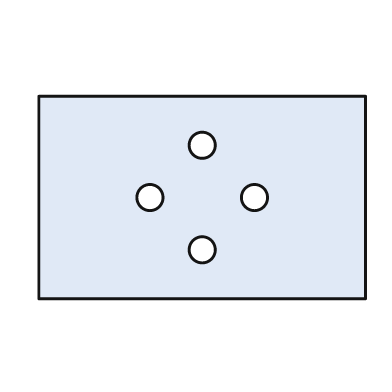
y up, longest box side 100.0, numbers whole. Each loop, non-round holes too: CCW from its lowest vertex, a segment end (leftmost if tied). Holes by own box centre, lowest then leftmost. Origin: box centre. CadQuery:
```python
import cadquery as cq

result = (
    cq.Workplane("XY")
    .moveTo(-50.0, -31.0)
    .lineTo(50.0, -31.0)
    .lineTo(50.0, 31.0)
    .lineTo(-50.0, 31.0)
    .close()
    .moveTo(0.0, -16.0)
    .circle(4.0)
    .moveTo(-16.0, 0.0)
    .circle(4.0)
    .moveTo(16.0, 0.0)
    .circle(4.0)
    .moveTo(0.0, 16.0)
    .circle(4.0)
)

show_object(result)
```